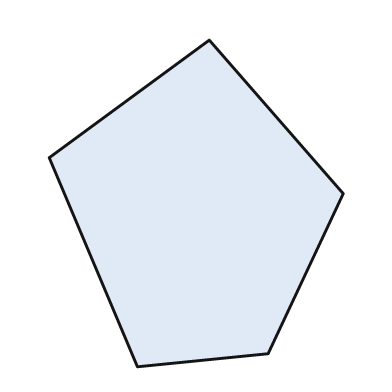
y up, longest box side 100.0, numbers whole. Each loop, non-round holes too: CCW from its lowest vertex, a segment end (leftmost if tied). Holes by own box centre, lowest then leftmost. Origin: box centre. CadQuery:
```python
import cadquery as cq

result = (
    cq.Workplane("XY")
    .moveTo(-18.0, -50.0)
    .lineTo(22.0, -46.0)
    .lineTo(45.0, 3.0)
    .lineTo(4.0, 50.0)
    .lineTo(-45.0, 14.0)
    .close()
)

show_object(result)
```